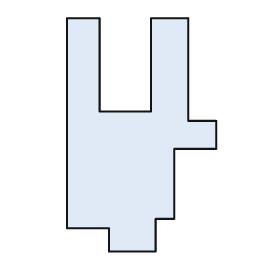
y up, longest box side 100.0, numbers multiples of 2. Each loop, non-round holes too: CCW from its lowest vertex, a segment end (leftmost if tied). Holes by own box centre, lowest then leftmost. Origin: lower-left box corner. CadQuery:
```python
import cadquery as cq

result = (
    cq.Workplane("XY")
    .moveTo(18.0, 0.0)
    .lineTo(38.0, 0.0)
    .lineTo(38.0, 14.0)
    .lineTo(46.0, 14.0)
    .lineTo(46.0, 44.0)
    .lineTo(64.0, 44.0)
    .lineTo(64.0, 56.0)
    .lineTo(52.0, 56.0)
    .lineTo(52.0, 100.0)
    .lineTo(36.0, 100.0)
    .lineTo(36.0, 60.0)
    .lineTo(14.0, 60.0)
    .lineTo(14.0, 100.0)
    .lineTo(0.0, 100.0)
    .lineTo(0.0, 10.0)
    .lineTo(18.0, 10.0)
    .close()
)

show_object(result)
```